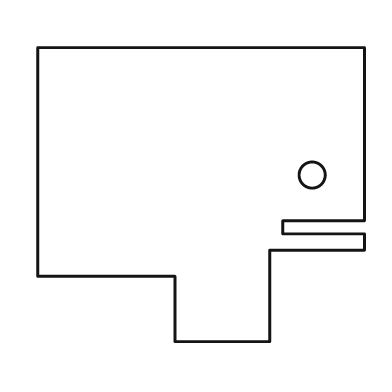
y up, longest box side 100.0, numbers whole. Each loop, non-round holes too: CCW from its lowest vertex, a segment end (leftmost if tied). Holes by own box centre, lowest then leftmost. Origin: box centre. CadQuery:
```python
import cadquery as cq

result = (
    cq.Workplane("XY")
    .moveTo(-8.0, -45.0)
    .lineTo(21.0, -45.0)
    .lineTo(21.0, -17.0)
    .lineTo(50.0, -17.0)
    .lineTo(50.0, -12.0)
    .lineTo(25.0, -12.0)
    .lineTo(25.0, -8.0)
    .lineTo(50.0, -8.0)
    .lineTo(50.0, 45.0)
    .lineTo(-50.0, 45.0)
    .lineTo(-50.0, -25.0)
    .lineTo(-8.0, -25.0)
    .close()
    .moveTo(34.0, 6.0)
    .circle(4.0)
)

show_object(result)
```